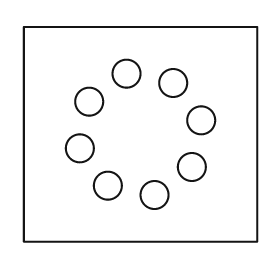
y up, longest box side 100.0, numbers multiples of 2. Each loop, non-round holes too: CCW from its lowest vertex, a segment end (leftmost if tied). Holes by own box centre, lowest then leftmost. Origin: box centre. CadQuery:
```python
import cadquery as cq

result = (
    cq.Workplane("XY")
    .moveTo(-50.0, -46.0)
    .lineTo(50.0, -46.0)
    .lineTo(50.0, 46.0)
    .lineTo(-50.0, 46.0)
    .close()
    .moveTo(6.0, -26.0)
    .circle(6.0)
    .moveTo(-14.0, -22.0)
    .circle(6.0)
    .moveTo(22.0, -14.0)
    .circle(6.0)
    .moveTo(-26.0, -6.0)
    .circle(6.0)
    .moveTo(26.0, 6.0)
    .circle(6.0)
    .moveTo(-22.0, 14.0)
    .circle(6.0)
    .moveTo(14.0, 22.0)
    .circle(6.0)
    .moveTo(-6.0, 26.0)
    .circle(6.0)
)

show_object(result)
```